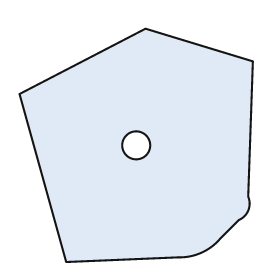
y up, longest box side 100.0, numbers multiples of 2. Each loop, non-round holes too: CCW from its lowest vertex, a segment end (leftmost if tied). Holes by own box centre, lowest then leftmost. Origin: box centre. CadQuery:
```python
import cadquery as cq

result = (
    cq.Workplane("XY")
    .moveTo(-30.0, -50.0)
    .lineTo(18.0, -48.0)
    .threePointArc((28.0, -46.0), (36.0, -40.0))
    .lineTo(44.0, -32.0)
    .threePointArc((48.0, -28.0), (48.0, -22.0))
    .lineTo(50.0, 36.0)
    .lineTo(4.0, 50.0)
    .lineTo(-50.0, 22.0)
    .close()
    .moveTo(0.0, 0.0)
    .circle(6.0)
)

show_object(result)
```